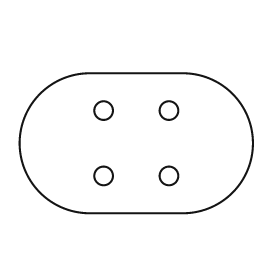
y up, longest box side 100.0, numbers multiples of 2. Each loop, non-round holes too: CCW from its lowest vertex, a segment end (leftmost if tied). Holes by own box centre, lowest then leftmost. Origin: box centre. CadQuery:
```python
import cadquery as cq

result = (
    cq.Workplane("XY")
    .moveTo(-20.0, -30.0)
    .lineTo(20.0, -30.0)
    .threePointArc((50.0, 0.0), (20.0, 30.0))
    .lineTo(-20.0, 30.0)
    .threePointArc((-50.0, 0.0), (-20.0, -30.0))
    .close()
    .moveTo(-14.0, -14.0)
    .circle(4.0)
    .moveTo(14.0, -14.0)
    .circle(4.0)
    .moveTo(-14.0, 14.0)
    .circle(4.0)
    .moveTo(14.0, 14.0)
    .circle(4.0)
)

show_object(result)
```